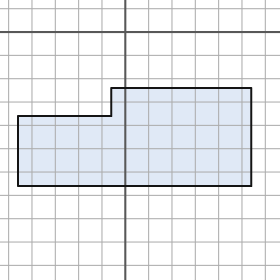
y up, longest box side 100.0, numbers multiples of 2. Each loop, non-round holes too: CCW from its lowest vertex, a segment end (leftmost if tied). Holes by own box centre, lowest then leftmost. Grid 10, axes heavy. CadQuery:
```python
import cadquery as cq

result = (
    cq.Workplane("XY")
    .moveTo(-46.0, -66.0)
    .lineTo(54.0, -66.0)
    .lineTo(54.0, -24.0)
    .lineTo(-6.0, -24.0)
    .lineTo(-6.0, -36.0)
    .lineTo(-46.0, -36.0)
    .close()
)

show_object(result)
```